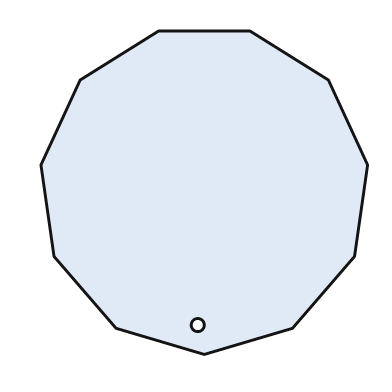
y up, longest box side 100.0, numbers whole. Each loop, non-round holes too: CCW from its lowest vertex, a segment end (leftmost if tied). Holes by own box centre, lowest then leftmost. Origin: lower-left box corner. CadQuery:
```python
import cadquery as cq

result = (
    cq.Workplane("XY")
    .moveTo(50.0, 0.0)
    .lineTo(77.0, 8.0)
    .lineTo(96.0, 30.0)
    .lineTo(100.0, 58.0)
    .lineTo(88.0, 84.0)
    .lineTo(64.0, 99.0)
    .lineTo(36.0, 99.0)
    .lineTo(12.0, 84.0)
    .lineTo(0.0, 58.0)
    .lineTo(4.0, 30.0)
    .lineTo(23.0, 8.0)
    .close()
    .moveTo(48.0, 9.0)
    .circle(2.0)
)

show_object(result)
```